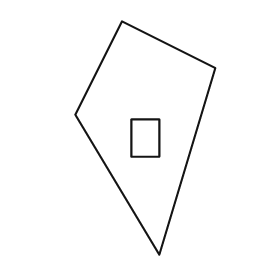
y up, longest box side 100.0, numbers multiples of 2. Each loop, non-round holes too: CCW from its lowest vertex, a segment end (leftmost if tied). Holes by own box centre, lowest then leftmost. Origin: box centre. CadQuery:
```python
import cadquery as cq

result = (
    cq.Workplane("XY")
    .moveTo(6.0, -50.0)
    .lineTo(30.0, 30.0)
    .lineTo(-10.0, 50.0)
    .lineTo(-30.0, 10.0)
    .close()
    .moveTo(-6.0, -8.0)
    .lineTo(6.0, -8.0)
    .lineTo(6.0, 8.0)
    .lineTo(-6.0, 8.0)
    .close()
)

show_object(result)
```